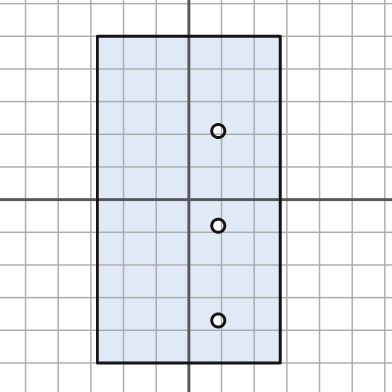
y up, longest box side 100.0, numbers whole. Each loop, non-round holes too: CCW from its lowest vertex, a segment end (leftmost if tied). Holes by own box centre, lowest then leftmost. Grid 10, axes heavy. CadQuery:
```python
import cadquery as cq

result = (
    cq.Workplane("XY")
    .moveTo(-28.0, -50.0)
    .lineTo(28.0, -50.0)
    .lineTo(28.0, 50.0)
    .lineTo(-28.0, 50.0)
    .close()
    .moveTo(9.0, -37.0)
    .circle(2.0)
    .moveTo(9.0, -8.0)
    .circle(2.0)
    .moveTo(9.0, 21.0)
    .circle(2.0)
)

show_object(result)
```